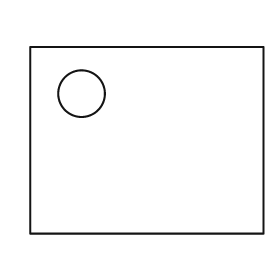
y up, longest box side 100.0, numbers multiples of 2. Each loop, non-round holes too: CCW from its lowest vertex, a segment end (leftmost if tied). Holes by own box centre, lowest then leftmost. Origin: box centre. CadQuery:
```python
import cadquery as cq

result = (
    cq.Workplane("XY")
    .moveTo(-50.0, -40.0)
    .lineTo(50.0, -40.0)
    .lineTo(50.0, 40.0)
    .lineTo(-50.0, 40.0)
    .close()
    .moveTo(-28.0, 20.0)
    .circle(10.0)
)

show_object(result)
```